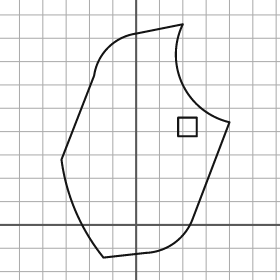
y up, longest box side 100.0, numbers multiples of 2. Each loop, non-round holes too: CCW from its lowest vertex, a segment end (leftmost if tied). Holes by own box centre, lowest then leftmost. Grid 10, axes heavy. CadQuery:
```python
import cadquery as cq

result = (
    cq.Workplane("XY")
    .moveTo(-14.0, -14.0)
    .lineTo(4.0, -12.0)
    .threePointArc((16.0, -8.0), (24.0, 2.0))
    .lineTo(40.0, 44.0)
    .threePointArc((20.0, 60.0), (20.0, 86.0))
    .lineTo(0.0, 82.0)
    .threePointArc((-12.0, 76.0), (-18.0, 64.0))
    .lineTo(-32.0, 28.0)
    .threePointArc((-26.0, 6.0), (-14.0, -14.0))
    .close()
    .moveTo(18.0, 38.0)
    .lineTo(26.0, 38.0)
    .lineTo(26.0, 46.0)
    .lineTo(18.0, 46.0)
    .close()
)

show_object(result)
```